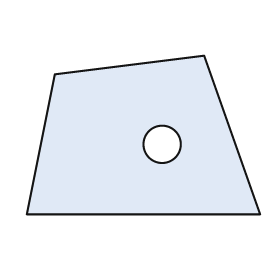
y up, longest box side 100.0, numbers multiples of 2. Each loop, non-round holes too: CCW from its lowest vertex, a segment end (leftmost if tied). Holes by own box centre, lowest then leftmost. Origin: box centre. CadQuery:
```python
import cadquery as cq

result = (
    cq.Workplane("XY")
    .moveTo(-50.0, -34.0)
    .lineTo(50.0, -34.0)
    .lineTo(26.0, 34.0)
    .lineTo(-38.0, 26.0)
    .close()
    .moveTo(8.0, -4.0)
    .circle(8.0)
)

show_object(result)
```